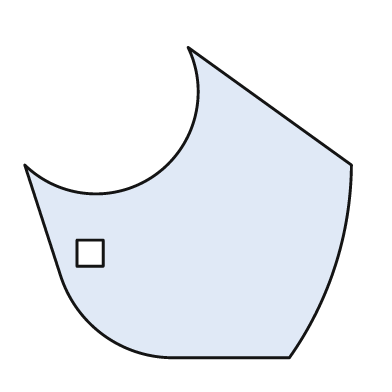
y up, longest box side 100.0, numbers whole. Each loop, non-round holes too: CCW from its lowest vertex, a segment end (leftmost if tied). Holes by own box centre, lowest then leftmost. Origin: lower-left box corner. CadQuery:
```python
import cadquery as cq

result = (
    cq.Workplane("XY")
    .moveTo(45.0, 0.0)
    .lineTo(81.0, 0.0)
    .threePointArc((95.0, 28.0), (100.0, 59.0))
    .lineTo(50.0, 95.0)
    .threePointArc((40.0, 56.0), (0.0, 59.0))
    .lineTo(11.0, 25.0)
    .threePointArc((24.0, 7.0), (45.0, 0.0))
    .close()
    .moveTo(16.0, 28.0)
    .lineTo(24.0, 28.0)
    .lineTo(24.0, 36.0)
    .lineTo(16.0, 36.0)
    .close()
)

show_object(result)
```